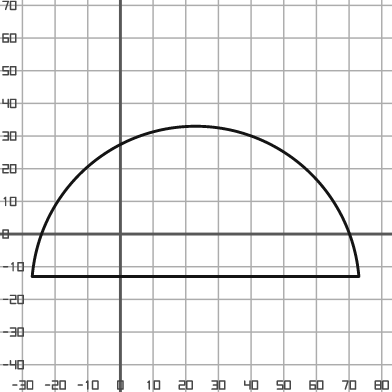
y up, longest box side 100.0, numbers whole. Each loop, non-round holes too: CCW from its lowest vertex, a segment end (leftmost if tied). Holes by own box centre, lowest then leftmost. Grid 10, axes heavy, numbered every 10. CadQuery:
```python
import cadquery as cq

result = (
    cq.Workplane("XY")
    .moveTo(-27.0, -13.0)
    .lineTo(73.0, -13.0)
    .threePointArc((23.0, 33.0), (-27.0, -13.0))
    .close()
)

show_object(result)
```